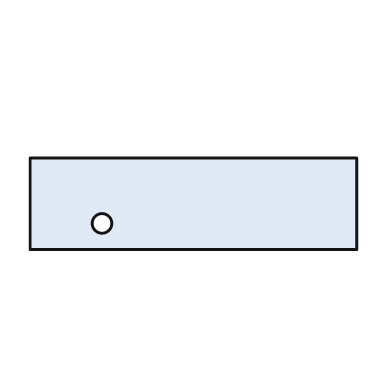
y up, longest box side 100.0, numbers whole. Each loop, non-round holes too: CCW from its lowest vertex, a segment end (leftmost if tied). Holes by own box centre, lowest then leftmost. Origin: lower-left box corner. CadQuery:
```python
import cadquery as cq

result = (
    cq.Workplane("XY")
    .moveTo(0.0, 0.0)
    .lineTo(100.0, 0.0)
    .lineTo(100.0, 28.0)
    .lineTo(0.0, 28.0)
    .close()
    .moveTo(22.0, 8.0)
    .circle(3.0)
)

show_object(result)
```